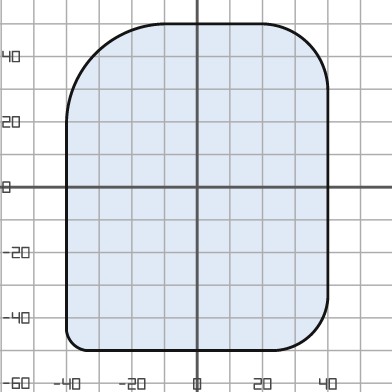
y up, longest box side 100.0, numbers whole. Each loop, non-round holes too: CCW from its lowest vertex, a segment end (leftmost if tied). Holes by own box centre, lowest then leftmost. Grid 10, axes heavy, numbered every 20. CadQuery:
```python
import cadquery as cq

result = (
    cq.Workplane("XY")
    .moveTo(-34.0, -50.0)
    .lineTo(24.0, -50.0)
    .threePointArc((35.0, -45.0), (40.0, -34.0))
    .lineTo(40.0, 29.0)
    .threePointArc((34.0, 44.0), (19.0, 50.0))
    .lineTo(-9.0, 50.0)
    .threePointArc((-31.0, 41.0), (-40.0, 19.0))
    .lineTo(-40.0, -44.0)
    .threePointArc((-38.0, -48.0), (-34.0, -50.0))
    .close()
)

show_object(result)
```